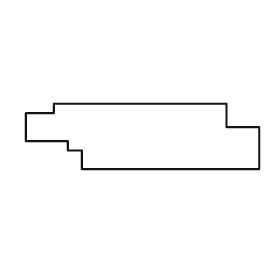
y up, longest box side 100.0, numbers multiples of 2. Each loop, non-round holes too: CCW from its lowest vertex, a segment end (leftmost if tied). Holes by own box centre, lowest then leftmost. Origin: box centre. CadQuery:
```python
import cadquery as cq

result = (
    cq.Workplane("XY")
    .moveTo(-26.0, -14.0)
    .lineTo(50.0, -14.0)
    .lineTo(50.0, 4.0)
    .lineTo(36.0, 4.0)
    .lineTo(36.0, 14.0)
    .lineTo(-38.0, 14.0)
    .lineTo(-38.0, 10.0)
    .lineTo(-50.0, 10.0)
    .lineTo(-50.0, -2.0)
    .lineTo(-32.0, -2.0)
    .lineTo(-32.0, -6.0)
    .lineTo(-26.0, -6.0)
    .close()
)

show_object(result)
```